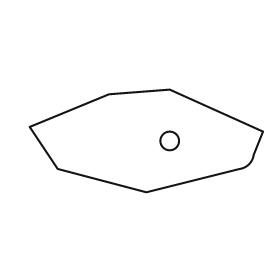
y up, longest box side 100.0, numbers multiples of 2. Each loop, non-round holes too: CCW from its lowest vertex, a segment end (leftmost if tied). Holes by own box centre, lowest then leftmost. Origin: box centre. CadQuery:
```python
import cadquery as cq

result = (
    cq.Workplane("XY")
    .moveTo(0.0, -22.0)
    .lineTo(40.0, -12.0)
    .threePointArc((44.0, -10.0), (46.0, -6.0))
    .lineTo(50.0, 4.0)
    .lineTo(10.0, 22.0)
    .lineTo(-16.0, 20.0)
    .lineTo(-50.0, 6.0)
    .lineTo(-38.0, -12.0)
    .close()
    .moveTo(10.0, 0.0)
    .circle(4.0)
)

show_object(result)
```